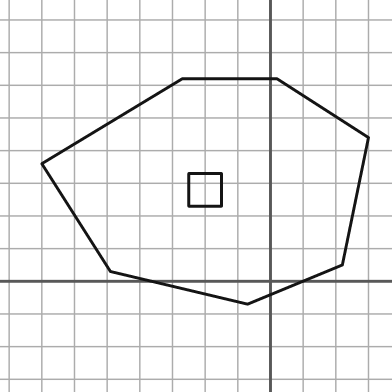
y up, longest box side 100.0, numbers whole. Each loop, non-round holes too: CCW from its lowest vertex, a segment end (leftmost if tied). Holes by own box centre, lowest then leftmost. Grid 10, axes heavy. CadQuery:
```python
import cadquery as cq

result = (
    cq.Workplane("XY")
    .moveTo(-7.0, -7.0)
    .lineTo(22.0, 5.0)
    .lineTo(30.0, 44.0)
    .lineTo(2.0, 62.0)
    .lineTo(-27.0, 62.0)
    .lineTo(-70.0, 36.0)
    .lineTo(-49.0, 3.0)
    .close()
    .moveTo(-25.0, 23.0)
    .lineTo(-15.0, 23.0)
    .lineTo(-15.0, 33.0)
    .lineTo(-25.0, 33.0)
    .close()
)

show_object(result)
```